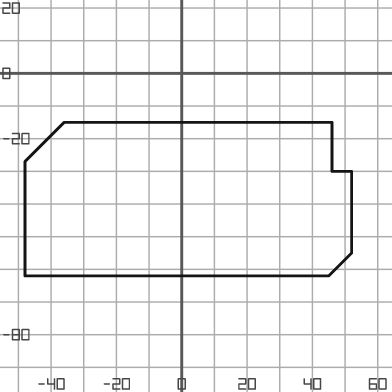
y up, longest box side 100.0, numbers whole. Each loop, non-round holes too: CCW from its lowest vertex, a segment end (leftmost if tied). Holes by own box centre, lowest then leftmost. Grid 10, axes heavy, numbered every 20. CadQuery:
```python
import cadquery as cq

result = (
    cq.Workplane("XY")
    .moveTo(-48.0, -62.0)
    .lineTo(45.0, -62.0)
    .lineTo(52.0, -55.0)
    .lineTo(52.0, -30.0)
    .lineTo(46.0, -30.0)
    .lineTo(46.0, -15.0)
    .lineTo(-36.0, -15.0)
    .lineTo(-48.0, -27.0)
    .close()
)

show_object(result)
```